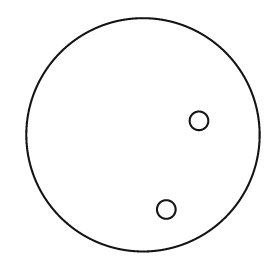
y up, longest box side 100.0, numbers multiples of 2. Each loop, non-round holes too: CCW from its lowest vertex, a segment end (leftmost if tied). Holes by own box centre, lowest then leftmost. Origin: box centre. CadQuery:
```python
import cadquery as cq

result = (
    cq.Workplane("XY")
    .moveTo(0.0, 0.0)
    .circle(50.0)
    .moveTo(10.0, -32.0)
    .circle(4.0)
    .moveTo(24.0, 6.0)
    .circle(4.0)
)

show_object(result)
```